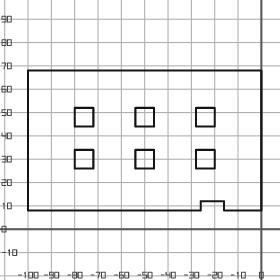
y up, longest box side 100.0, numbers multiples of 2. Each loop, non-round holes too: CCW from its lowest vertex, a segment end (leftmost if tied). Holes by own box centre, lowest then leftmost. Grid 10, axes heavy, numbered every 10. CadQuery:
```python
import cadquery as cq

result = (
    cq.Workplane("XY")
    .moveTo(-100.0, 8.0)
    .lineTo(-26.0, 8.0)
    .lineTo(-26.0, 12.0)
    .lineTo(-16.0, 12.0)
    .lineTo(-16.0, 8.0)
    .lineTo(0.0, 8.0)
    .lineTo(0.0, 68.0)
    .lineTo(-100.0, 68.0)
    .close()
    .moveTo(-80.0, 26.0)
    .lineTo(-72.0, 26.0)
    .lineTo(-72.0, 34.0)
    .lineTo(-80.0, 34.0)
    .close()
    .moveTo(-54.0, 26.0)
    .lineTo(-46.0, 26.0)
    .lineTo(-46.0, 34.0)
    .lineTo(-54.0, 34.0)
    .close()
    .moveTo(-28.0, 26.0)
    .lineTo(-20.0, 26.0)
    .lineTo(-20.0, 34.0)
    .lineTo(-28.0, 34.0)
    .close()
    .moveTo(-80.0, 44.0)
    .lineTo(-72.0, 44.0)
    .lineTo(-72.0, 52.0)
    .lineTo(-80.0, 52.0)
    .close()
    .moveTo(-54.0, 44.0)
    .lineTo(-46.0, 44.0)
    .lineTo(-46.0, 52.0)
    .lineTo(-54.0, 52.0)
    .close()
    .moveTo(-28.0, 44.0)
    .lineTo(-20.0, 44.0)
    .lineTo(-20.0, 52.0)
    .lineTo(-28.0, 52.0)
    .close()
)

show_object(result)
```